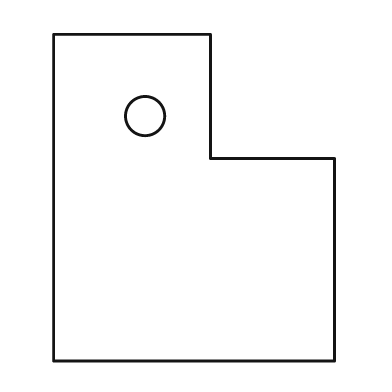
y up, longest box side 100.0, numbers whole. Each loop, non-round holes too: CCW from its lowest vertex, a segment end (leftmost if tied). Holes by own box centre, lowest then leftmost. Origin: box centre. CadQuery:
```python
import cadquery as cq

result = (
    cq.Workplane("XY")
    .moveTo(-43.0, -50.0)
    .lineTo(43.0, -50.0)
    .lineTo(43.0, 12.0)
    .lineTo(5.0, 12.0)
    .lineTo(5.0, 50.0)
    .lineTo(-43.0, 50.0)
    .close()
    .moveTo(-15.0, 25.0)
    .circle(6.0)
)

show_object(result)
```